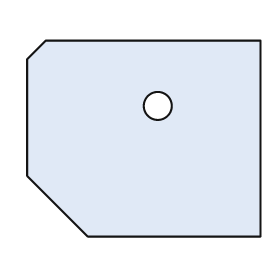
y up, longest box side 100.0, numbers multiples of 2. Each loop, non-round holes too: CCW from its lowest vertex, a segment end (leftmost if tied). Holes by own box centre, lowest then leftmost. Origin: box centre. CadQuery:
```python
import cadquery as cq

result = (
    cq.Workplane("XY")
    .moveTo(-24.0, -42.0)
    .lineTo(50.0, -42.0)
    .lineTo(50.0, 42.0)
    .lineTo(-42.0, 42.0)
    .lineTo(-50.0, 34.0)
    .lineTo(-50.0, -16.0)
    .close()
    .moveTo(6.0, 14.0)
    .circle(6.0)
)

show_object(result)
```